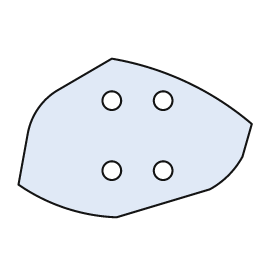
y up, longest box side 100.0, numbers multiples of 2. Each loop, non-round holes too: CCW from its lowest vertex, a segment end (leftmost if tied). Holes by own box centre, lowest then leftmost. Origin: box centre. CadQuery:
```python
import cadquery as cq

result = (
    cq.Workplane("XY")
    .moveTo(-8.0, -34.0)
    .lineTo(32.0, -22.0)
    .threePointArc((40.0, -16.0), (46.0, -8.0))
    .lineTo(50.0, 6.0)
    .threePointArc((22.0, 24.0), (-10.0, 34.0))
    .lineTo(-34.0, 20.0)
    .threePointArc((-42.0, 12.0), (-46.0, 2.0))
    .lineTo(-50.0, -20.0)
    .threePointArc((-30.0, -30.0), (-8.0, -34.0))
    .close()
    .moveTo(-10.0, -14.0)
    .circle(4.0)
    .moveTo(12.0, -14.0)
    .circle(4.0)
    .moveTo(-10.0, 16.0)
    .circle(4.0)
    .moveTo(12.0, 16.0)
    .circle(4.0)
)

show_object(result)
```